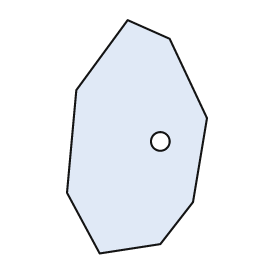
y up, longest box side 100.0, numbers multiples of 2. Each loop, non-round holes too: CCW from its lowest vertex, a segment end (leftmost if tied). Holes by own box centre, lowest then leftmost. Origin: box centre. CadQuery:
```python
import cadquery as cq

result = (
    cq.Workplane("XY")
    .moveTo(-16.0, -50.0)
    .lineTo(10.0, -46.0)
    .lineTo(24.0, -28.0)
    .lineTo(30.0, 8.0)
    .lineTo(14.0, 42.0)
    .lineTo(-4.0, 50.0)
    .lineTo(-26.0, 20.0)
    .lineTo(-30.0, -24.0)
    .close()
    .moveTo(10.0, -2.0)
    .circle(4.0)
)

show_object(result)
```